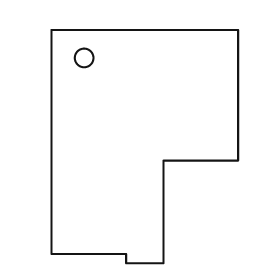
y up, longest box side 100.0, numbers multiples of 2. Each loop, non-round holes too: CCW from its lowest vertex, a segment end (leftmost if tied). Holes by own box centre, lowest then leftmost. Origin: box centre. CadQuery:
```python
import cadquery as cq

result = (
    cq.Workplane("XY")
    .moveTo(-8.0, -50.0)
    .lineTo(8.0, -50.0)
    .lineTo(8.0, -6.0)
    .lineTo(40.0, -6.0)
    .lineTo(40.0, 50.0)
    .lineTo(-40.0, 50.0)
    .lineTo(-40.0, -46.0)
    .lineTo(-8.0, -46.0)
    .close()
    .moveTo(-26.0, 38.0)
    .circle(4.0)
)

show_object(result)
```